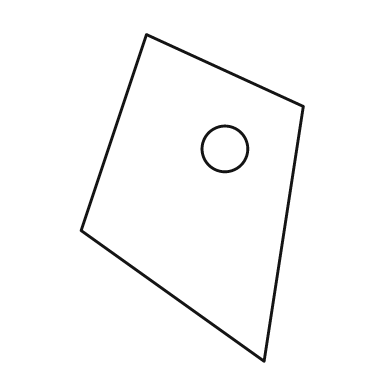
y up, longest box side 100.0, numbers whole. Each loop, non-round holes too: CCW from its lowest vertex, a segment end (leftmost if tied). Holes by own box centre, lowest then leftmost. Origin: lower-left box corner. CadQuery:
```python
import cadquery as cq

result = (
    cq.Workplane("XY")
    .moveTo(56.0, 0.0)
    .lineTo(68.0, 78.0)
    .lineTo(20.0, 100.0)
    .lineTo(0.0, 40.0)
    .close()
    .moveTo(44.0, 65.0)
    .circle(7.0)
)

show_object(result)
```